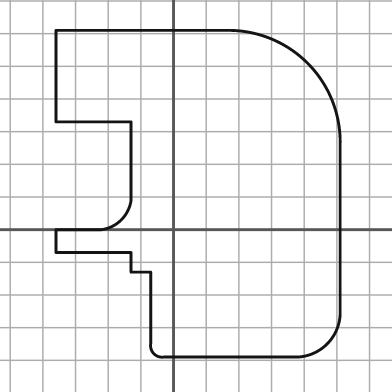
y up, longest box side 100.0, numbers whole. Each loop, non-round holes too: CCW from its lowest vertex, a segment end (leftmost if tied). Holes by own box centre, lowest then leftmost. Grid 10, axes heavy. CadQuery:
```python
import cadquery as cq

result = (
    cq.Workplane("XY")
    .moveTo(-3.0, -39.0)
    .lineTo(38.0, -39.0)
    .threePointArc((47.0, -35.0), (51.0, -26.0))
    .lineTo(51.0, 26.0)
    .threePointArc((41.0, 51.0), (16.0, 61.0))
    .lineTo(-36.0, 61.0)
    .lineTo(-36.0, 33.0)
    .lineTo(-13.0, 33.0)
    .lineTo(-13.0, 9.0)
    .threePointArc((-16.0, 3.0), (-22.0, 0.0))
    .lineTo(-36.0, 0.0)
    .lineTo(-36.0, -7.0)
    .lineTo(-13.0, -7.0)
    .lineTo(-13.0, -13.0)
    .lineTo(-7.0, -13.0)
    .lineTo(-7.0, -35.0)
    .threePointArc((-6.0, -38.0), (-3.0, -39.0))
    .close()
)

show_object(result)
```